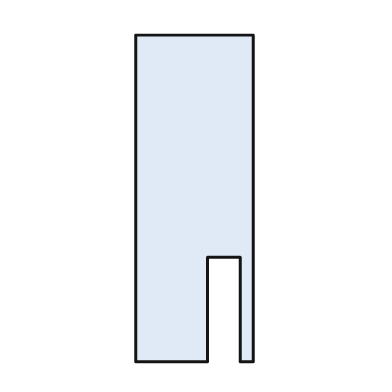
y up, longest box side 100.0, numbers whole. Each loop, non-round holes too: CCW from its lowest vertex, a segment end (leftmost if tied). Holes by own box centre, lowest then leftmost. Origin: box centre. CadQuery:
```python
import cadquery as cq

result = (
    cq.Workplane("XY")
    .moveTo(-18.0, -50.0)
    .lineTo(4.0, -50.0)
    .lineTo(4.0, -18.0)
    .lineTo(14.0, -18.0)
    .lineTo(14.0, -50.0)
    .lineTo(18.0, -50.0)
    .lineTo(18.0, 50.0)
    .lineTo(-18.0, 50.0)
    .close()
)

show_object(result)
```